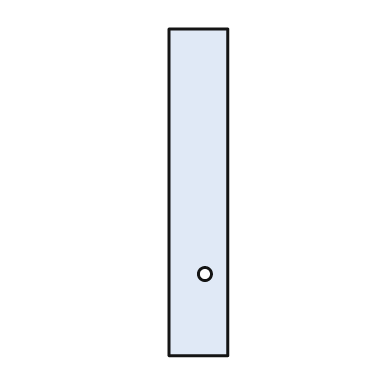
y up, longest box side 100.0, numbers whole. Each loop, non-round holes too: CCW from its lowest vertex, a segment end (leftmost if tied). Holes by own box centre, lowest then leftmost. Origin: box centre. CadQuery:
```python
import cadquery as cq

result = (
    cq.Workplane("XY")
    .moveTo(-9.0, -50.0)
    .lineTo(9.0, -50.0)
    .lineTo(9.0, 50.0)
    .lineTo(-9.0, 50.0)
    .close()
    .moveTo(2.0, -25.0)
    .circle(2.0)
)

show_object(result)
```